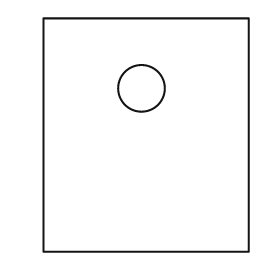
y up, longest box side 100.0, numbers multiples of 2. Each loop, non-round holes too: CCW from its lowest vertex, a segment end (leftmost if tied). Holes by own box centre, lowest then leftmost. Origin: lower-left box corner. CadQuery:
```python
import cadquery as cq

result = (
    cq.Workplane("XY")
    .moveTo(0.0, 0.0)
    .lineTo(88.0, 0.0)
    .lineTo(88.0, 100.0)
    .lineTo(0.0, 100.0)
    .close()
    .moveTo(42.0, 70.0)
    .circle(10.0)
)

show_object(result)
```